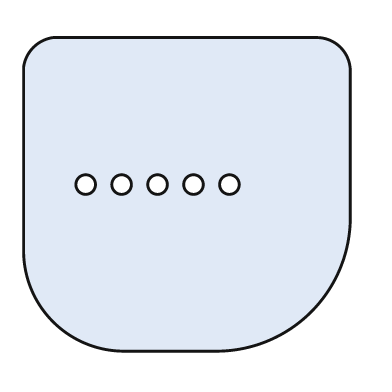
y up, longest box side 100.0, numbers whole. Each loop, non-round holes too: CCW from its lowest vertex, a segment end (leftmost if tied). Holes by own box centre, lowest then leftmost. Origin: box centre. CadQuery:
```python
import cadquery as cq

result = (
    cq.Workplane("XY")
    .moveTo(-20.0, -48.0)
    .lineTo(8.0, -48.0)
    .threePointArc((38.0, -36.0), (50.0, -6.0))
    .lineTo(50.0, 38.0)
    .threePointArc((47.0, 45.0), (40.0, 48.0))
    .lineTo(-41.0, 48.0)
    .threePointArc((-47.0, 45.0), (-50.0, 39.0))
    .lineTo(-50.0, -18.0)
    .threePointArc((-41.0, -39.0), (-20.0, -48.0))
    .close()
    .moveTo(-31.0, 3.0)
    .circle(3.0)
    .moveTo(-20.0, 3.0)
    .circle(3.0)
    .moveTo(-9.0, 3.0)
    .circle(3.0)
    .moveTo(2.0, 3.0)
    .circle(3.0)
    .moveTo(13.0, 3.0)
    .circle(3.0)
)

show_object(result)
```